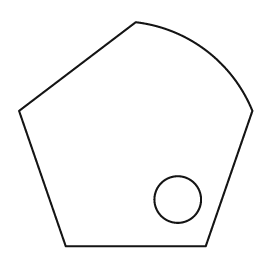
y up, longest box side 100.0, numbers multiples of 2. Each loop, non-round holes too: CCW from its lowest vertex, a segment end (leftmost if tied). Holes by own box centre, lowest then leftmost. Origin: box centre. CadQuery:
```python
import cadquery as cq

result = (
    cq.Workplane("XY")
    .moveTo(-30.0, -48.0)
    .lineTo(30.0, -48.0)
    .lineTo(50.0, 10.0)
    .threePointArc((30.0, 36.0), (0.0, 48.0))
    .lineTo(-50.0, 10.0)
    .close()
    .moveTo(18.0, -28.0)
    .circle(10.0)
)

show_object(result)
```